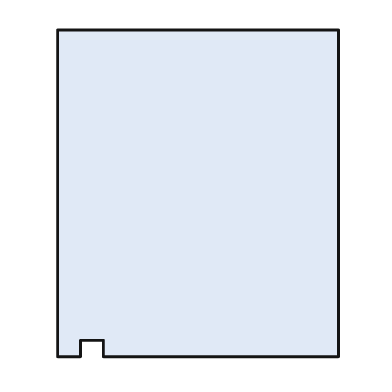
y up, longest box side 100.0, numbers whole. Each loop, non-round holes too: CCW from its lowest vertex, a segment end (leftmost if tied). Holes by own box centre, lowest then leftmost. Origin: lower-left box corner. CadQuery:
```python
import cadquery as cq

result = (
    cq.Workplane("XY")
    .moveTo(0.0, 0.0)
    .lineTo(7.0, 0.0)
    .lineTo(7.0, 5.0)
    .lineTo(14.0, 5.0)
    .lineTo(14.0, 0.0)
    .lineTo(86.0, 0.0)
    .lineTo(86.0, 100.0)
    .lineTo(0.0, 100.0)
    .close()
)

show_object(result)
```